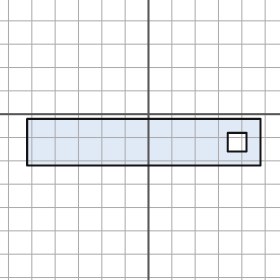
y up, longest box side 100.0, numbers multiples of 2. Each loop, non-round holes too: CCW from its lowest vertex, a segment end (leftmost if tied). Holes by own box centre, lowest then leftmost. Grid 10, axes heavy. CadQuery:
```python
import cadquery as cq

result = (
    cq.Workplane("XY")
    .moveTo(-52.0, -22.0)
    .lineTo(48.0, -22.0)
    .lineTo(48.0, -2.0)
    .lineTo(-52.0, -2.0)
    .close()
    .moveTo(34.0, -16.0)
    .lineTo(42.0, -16.0)
    .lineTo(42.0, -8.0)
    .lineTo(34.0, -8.0)
    .close()
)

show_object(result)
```